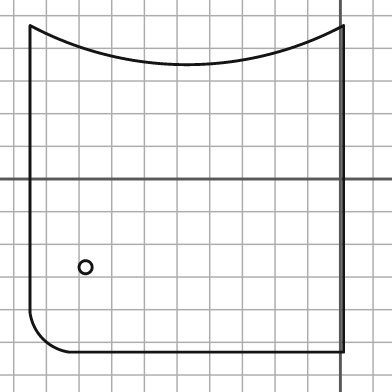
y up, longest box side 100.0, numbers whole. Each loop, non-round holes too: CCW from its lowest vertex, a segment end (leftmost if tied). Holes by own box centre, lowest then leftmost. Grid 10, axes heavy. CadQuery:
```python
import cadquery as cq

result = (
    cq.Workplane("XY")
    .moveTo(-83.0, -53.0)
    .lineTo(1.0, -53.0)
    .lineTo(1.0, 47.0)
    .threePointArc((-47.0, 35.0), (-95.0, 47.0))
    .lineTo(-95.0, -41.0)
    .threePointArc((-91.0, -49.0), (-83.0, -53.0))
    .close()
    .moveTo(-78.0, -27.0)
    .circle(2.0)
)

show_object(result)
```